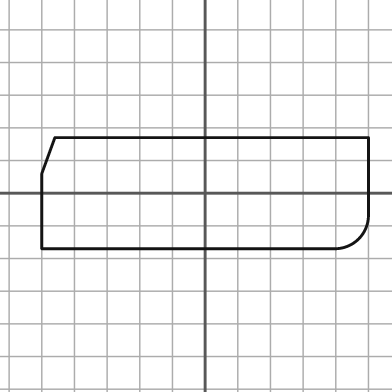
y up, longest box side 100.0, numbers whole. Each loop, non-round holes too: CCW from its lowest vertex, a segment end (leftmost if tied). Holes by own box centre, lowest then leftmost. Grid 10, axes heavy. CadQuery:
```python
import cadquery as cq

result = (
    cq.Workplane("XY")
    .moveTo(-50.0, -17.0)
    .lineTo(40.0, -17.0)
    .threePointArc((47.0, -14.0), (50.0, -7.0))
    .lineTo(50.0, 17.0)
    .lineTo(-46.0, 17.0)
    .lineTo(-50.0, 6.0)
    .close()
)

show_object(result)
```